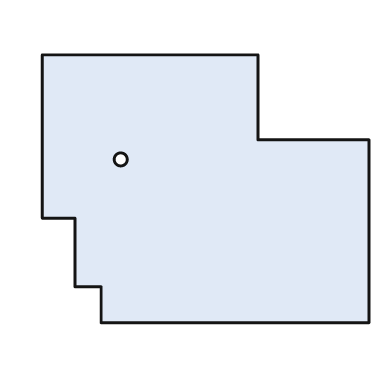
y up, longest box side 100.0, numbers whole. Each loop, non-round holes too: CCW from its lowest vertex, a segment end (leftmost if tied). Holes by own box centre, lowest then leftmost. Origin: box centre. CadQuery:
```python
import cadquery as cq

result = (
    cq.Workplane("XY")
    .moveTo(-32.0, -41.0)
    .lineTo(50.0, -41.0)
    .lineTo(50.0, 15.0)
    .lineTo(16.0, 15.0)
    .lineTo(16.0, 41.0)
    .lineTo(-50.0, 41.0)
    .lineTo(-50.0, -9.0)
    .lineTo(-40.0, -9.0)
    .lineTo(-40.0, -30.0)
    .lineTo(-32.0, -30.0)
    .close()
    .moveTo(-26.0, 9.0)
    .circle(2.0)
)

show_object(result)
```